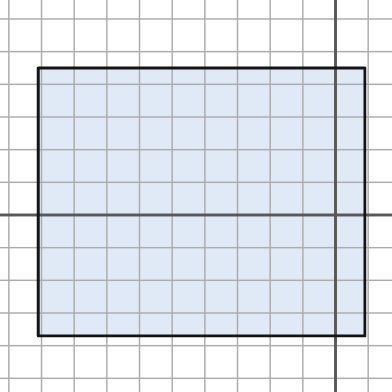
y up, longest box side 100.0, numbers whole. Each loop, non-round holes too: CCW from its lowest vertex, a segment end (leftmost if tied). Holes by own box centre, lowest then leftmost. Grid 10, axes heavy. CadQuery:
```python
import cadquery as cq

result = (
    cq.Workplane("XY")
    .moveTo(-91.0, -37.0)
    .lineTo(9.0, -37.0)
    .lineTo(9.0, 45.0)
    .lineTo(-91.0, 45.0)
    .close()
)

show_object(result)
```